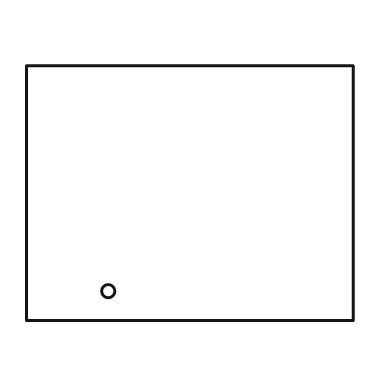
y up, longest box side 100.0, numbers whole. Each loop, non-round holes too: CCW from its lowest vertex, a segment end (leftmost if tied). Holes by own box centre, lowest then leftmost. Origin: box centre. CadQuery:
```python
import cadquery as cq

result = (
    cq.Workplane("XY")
    .moveTo(-50.0, -39.0)
    .lineTo(50.0, -39.0)
    .lineTo(50.0, 39.0)
    .lineTo(-50.0, 39.0)
    .close()
    .moveTo(-25.0, -30.0)
    .circle(2.0)
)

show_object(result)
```